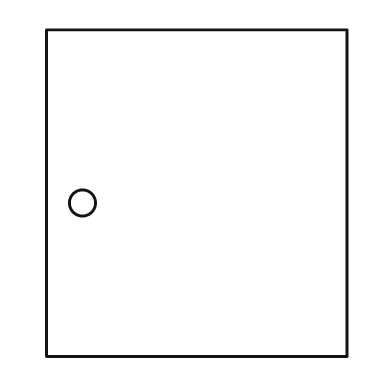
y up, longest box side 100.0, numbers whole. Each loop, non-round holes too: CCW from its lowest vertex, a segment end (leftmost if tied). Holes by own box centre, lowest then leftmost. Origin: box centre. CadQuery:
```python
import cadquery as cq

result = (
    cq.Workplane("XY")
    .moveTo(-46.0, -50.0)
    .lineTo(46.0, -50.0)
    .lineTo(46.0, 50.0)
    .lineTo(-46.0, 50.0)
    .close()
    .moveTo(-35.0, -3.0)
    .circle(4.0)
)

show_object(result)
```